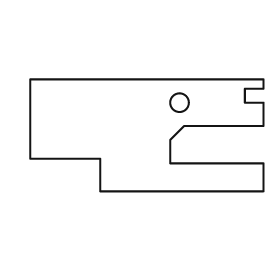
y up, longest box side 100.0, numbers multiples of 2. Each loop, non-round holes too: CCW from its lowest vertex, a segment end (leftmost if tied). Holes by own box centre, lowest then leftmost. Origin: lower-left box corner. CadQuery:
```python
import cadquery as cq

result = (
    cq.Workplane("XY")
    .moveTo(30.0, 0.0)
    .lineTo(100.0, 0.0)
    .lineTo(100.0, 12.0)
    .lineTo(60.0, 12.0)
    .lineTo(60.0, 22.0)
    .lineTo(66.0, 28.0)
    .lineTo(100.0, 28.0)
    .lineTo(100.0, 38.0)
    .lineTo(92.0, 38.0)
    .lineTo(92.0, 44.0)
    .lineTo(100.0, 44.0)
    .lineTo(100.0, 48.0)
    .lineTo(0.0, 48.0)
    .lineTo(0.0, 14.0)
    .lineTo(30.0, 14.0)
    .close()
    .moveTo(64.0, 38.0)
    .circle(4.0)
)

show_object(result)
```